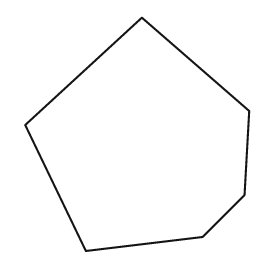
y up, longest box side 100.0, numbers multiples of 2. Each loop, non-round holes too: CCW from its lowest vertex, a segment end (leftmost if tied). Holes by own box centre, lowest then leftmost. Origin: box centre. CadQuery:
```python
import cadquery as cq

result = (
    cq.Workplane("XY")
    .moveTo(-22.0, -50.0)
    .lineTo(28.0, -44.0)
    .lineTo(46.0, -26.0)
    .lineTo(48.0, 10.0)
    .lineTo(2.0, 50.0)
    .lineTo(-48.0, 4.0)
    .close()
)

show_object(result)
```